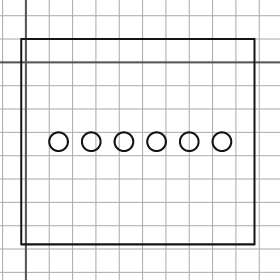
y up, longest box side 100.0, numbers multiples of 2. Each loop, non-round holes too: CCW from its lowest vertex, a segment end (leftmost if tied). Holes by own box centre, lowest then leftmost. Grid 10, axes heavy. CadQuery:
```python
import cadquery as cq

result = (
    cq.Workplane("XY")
    .moveTo(-2.0, -78.0)
    .lineTo(98.0, -78.0)
    .lineTo(98.0, 10.0)
    .lineTo(-2.0, 10.0)
    .close()
    .moveTo(14.0, -34.0)
    .circle(4.0)
    .moveTo(28.0, -34.0)
    .circle(4.0)
    .moveTo(42.0, -34.0)
    .circle(4.0)
    .moveTo(56.0, -34.0)
    .circle(4.0)
    .moveTo(70.0, -34.0)
    .circle(4.0)
    .moveTo(84.0, -34.0)
    .circle(4.0)
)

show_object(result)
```